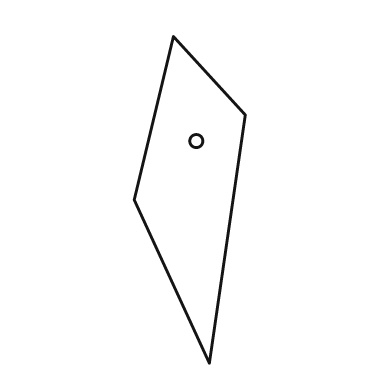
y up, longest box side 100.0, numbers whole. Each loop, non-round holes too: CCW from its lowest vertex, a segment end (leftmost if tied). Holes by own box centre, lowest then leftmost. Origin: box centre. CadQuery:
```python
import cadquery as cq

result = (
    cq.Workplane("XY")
    .moveTo(6.0, -50.0)
    .lineTo(17.0, 26.0)
    .lineTo(-5.0, 50.0)
    .lineTo(-17.0, 0.0)
    .close()
    .moveTo(2.0, 18.0)
    .circle(2.0)
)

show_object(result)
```